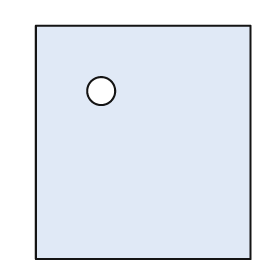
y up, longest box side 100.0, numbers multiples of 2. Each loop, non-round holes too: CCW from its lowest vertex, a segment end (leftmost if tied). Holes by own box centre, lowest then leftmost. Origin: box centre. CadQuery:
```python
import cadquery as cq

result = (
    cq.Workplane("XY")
    .moveTo(-46.0, -50.0)
    .lineTo(46.0, -50.0)
    .lineTo(46.0, 50.0)
    .lineTo(-46.0, 50.0)
    .close()
    .moveTo(-18.0, 22.0)
    .circle(6.0)
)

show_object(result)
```